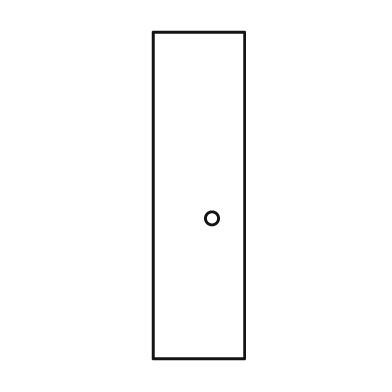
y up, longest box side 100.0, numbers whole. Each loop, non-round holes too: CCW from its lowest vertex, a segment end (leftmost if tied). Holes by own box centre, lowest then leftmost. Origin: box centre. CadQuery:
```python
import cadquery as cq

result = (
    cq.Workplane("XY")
    .moveTo(-14.0, -50.0)
    .lineTo(14.0, -50.0)
    .lineTo(14.0, 50.0)
    .lineTo(-14.0, 50.0)
    .close()
    .moveTo(4.0, -7.0)
    .circle(2.0)
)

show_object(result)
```